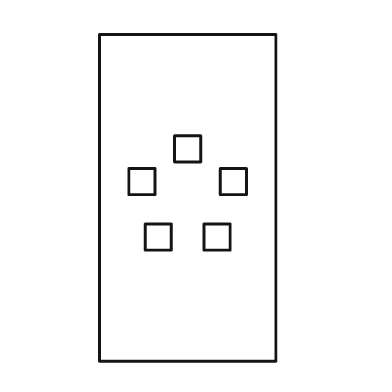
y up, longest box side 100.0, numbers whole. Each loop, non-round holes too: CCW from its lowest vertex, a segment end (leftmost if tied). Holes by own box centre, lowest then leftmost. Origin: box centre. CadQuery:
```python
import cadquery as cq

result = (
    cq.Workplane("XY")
    .moveTo(-27.0, -50.0)
    .lineTo(27.0, -50.0)
    .lineTo(27.0, 50.0)
    .lineTo(-27.0, 50.0)
    .close()
    .moveTo(-13.0, -16.0)
    .lineTo(-5.0, -16.0)
    .lineTo(-5.0, -8.0)
    .lineTo(-13.0, -8.0)
    .close()
    .moveTo(5.0, -16.0)
    .lineTo(13.0, -16.0)
    .lineTo(13.0, -8.0)
    .lineTo(5.0, -8.0)
    .close()
    .moveTo(-18.0, 1.0)
    .lineTo(-10.0, 1.0)
    .lineTo(-10.0, 9.0)
    .lineTo(-18.0, 9.0)
    .close()
    .moveTo(10.0, 1.0)
    .lineTo(18.0, 1.0)
    .lineTo(18.0, 9.0)
    .lineTo(10.0, 9.0)
    .close()
    .moveTo(-4.0, 11.0)
    .lineTo(4.0, 11.0)
    .lineTo(4.0, 19.0)
    .lineTo(-4.0, 19.0)
    .close()
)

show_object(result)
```